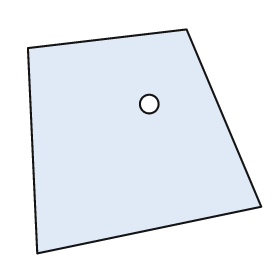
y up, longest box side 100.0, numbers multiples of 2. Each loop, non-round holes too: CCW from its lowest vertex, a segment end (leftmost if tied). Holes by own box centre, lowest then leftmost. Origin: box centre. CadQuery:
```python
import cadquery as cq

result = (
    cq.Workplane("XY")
    .moveTo(-46.0, -48.0)
    .lineTo(50.0, -28.0)
    .lineTo(18.0, 48.0)
    .lineTo(-50.0, 40.0)
    .close()
    .moveTo(2.0, 16.0)
    .circle(4.0)
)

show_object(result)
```